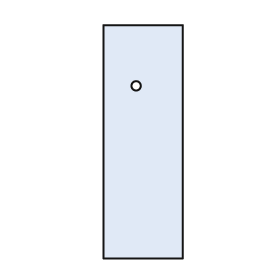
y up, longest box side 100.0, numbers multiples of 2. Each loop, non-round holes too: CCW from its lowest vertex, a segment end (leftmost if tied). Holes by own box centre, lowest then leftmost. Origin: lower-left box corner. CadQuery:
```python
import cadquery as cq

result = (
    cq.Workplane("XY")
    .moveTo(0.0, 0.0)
    .lineTo(34.0, 0.0)
    .lineTo(34.0, 100.0)
    .lineTo(0.0, 100.0)
    .close()
    .moveTo(14.0, 74.0)
    .circle(2.0)
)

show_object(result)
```